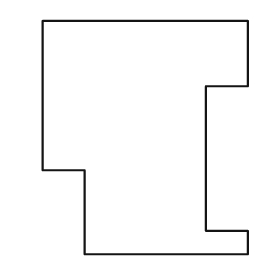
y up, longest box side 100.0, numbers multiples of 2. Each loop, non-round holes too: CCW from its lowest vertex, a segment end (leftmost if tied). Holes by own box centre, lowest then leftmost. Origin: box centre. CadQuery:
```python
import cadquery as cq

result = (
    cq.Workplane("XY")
    .moveTo(-26.0, -50.0)
    .lineTo(44.0, -50.0)
    .lineTo(44.0, -40.0)
    .lineTo(26.0, -40.0)
    .lineTo(26.0, 22.0)
    .lineTo(44.0, 22.0)
    .lineTo(44.0, 50.0)
    .lineTo(-44.0, 50.0)
    .lineTo(-44.0, -14.0)
    .lineTo(-26.0, -14.0)
    .close()
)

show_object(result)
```